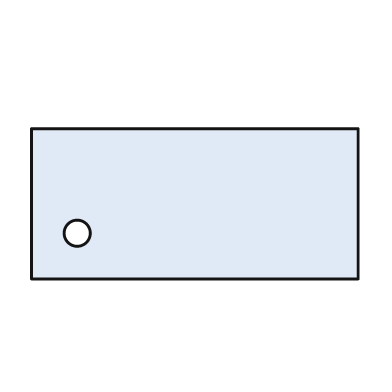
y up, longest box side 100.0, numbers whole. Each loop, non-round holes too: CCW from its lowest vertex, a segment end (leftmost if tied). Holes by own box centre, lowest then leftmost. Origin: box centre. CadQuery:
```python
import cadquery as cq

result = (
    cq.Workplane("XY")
    .moveTo(-50.0, -23.0)
    .lineTo(50.0, -23.0)
    .lineTo(50.0, 23.0)
    .lineTo(-50.0, 23.0)
    .close()
    .moveTo(-36.0, -9.0)
    .circle(4.0)
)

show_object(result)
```